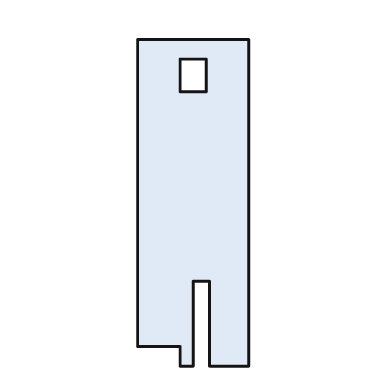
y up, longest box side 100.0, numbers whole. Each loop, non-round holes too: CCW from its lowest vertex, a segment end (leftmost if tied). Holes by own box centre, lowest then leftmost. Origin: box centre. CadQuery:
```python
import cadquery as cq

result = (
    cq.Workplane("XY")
    .moveTo(-4.0, -50.0)
    .lineTo(0.0, -50.0)
    .lineTo(0.0, -24.0)
    .lineTo(5.0, -24.0)
    .lineTo(5.0, -50.0)
    .lineTo(17.0, -50.0)
    .lineTo(17.0, 50.0)
    .lineTo(-17.0, 50.0)
    .lineTo(-17.0, -44.0)
    .lineTo(-4.0, -44.0)
    .close()
    .moveTo(-4.0, 34.0)
    .lineTo(4.0, 34.0)
    .lineTo(4.0, 44.0)
    .lineTo(-4.0, 44.0)
    .close()
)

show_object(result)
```